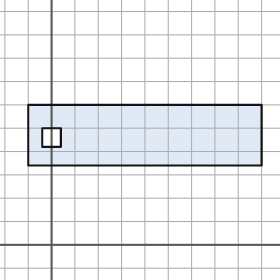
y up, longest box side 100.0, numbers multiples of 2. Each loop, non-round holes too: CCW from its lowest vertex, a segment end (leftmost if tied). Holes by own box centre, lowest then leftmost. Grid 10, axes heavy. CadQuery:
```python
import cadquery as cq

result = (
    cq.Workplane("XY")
    .moveTo(-10.0, 34.0)
    .lineTo(90.0, 34.0)
    .lineTo(90.0, 60.0)
    .lineTo(-10.0, 60.0)
    .close()
    .moveTo(-4.0, 42.0)
    .lineTo(4.0, 42.0)
    .lineTo(4.0, 50.0)
    .lineTo(-4.0, 50.0)
    .close()
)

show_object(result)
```